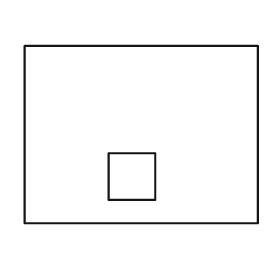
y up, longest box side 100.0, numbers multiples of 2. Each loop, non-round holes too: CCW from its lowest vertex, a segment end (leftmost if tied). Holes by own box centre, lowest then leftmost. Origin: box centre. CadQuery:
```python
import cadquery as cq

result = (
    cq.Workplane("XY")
    .moveTo(-50.0, -38.0)
    .lineTo(50.0, -38.0)
    .lineTo(50.0, 38.0)
    .lineTo(-50.0, 38.0)
    .close()
    .moveTo(-14.0, -28.0)
    .lineTo(6.0, -28.0)
    .lineTo(6.0, -8.0)
    .lineTo(-14.0, -8.0)
    .close()
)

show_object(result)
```